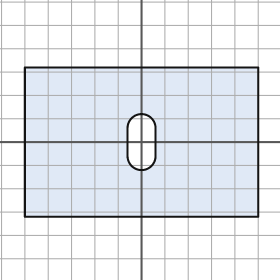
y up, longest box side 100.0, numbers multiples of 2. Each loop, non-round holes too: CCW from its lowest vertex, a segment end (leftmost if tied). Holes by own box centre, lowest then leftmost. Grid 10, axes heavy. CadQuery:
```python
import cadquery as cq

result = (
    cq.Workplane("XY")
    .moveTo(-50.0, -32.0)
    .lineTo(50.0, -32.0)
    .lineTo(50.0, 32.0)
    .lineTo(-50.0, 32.0)
    .close()
    .moveTo(-6.0, -6.0)
    .threePointArc((0.0, -12.0), (6.0, -6.0))
    .lineTo(6.0, 6.0)
    .threePointArc((0.0, 12.0), (-6.0, 6.0))
    .close()
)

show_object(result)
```